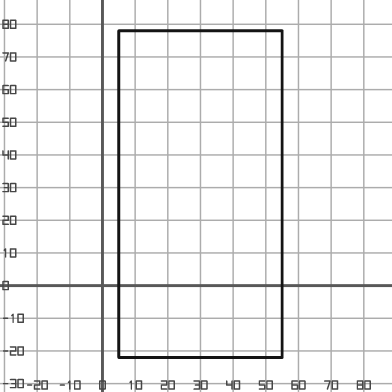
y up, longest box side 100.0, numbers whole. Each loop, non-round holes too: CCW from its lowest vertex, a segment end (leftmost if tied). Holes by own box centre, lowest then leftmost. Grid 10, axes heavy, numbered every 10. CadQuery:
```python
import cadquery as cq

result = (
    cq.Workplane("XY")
    .moveTo(5.0, -22.0)
    .lineTo(55.0, -22.0)
    .lineTo(55.0, 78.0)
    .lineTo(5.0, 78.0)
    .close()
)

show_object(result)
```